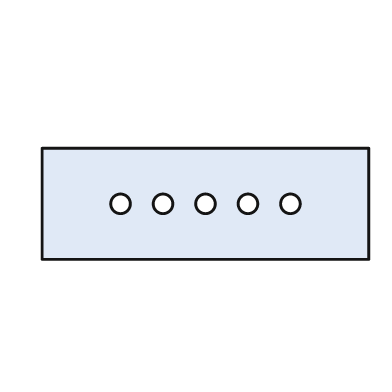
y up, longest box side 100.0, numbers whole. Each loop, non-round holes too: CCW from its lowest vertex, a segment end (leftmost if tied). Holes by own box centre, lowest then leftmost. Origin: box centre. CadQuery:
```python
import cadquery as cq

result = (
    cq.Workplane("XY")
    .moveTo(-50.0, -17.0)
    .lineTo(50.0, -17.0)
    .lineTo(50.0, 17.0)
    .lineTo(-50.0, 17.0)
    .close()
    .moveTo(-26.0, 0.0)
    .circle(3.0)
    .moveTo(-13.0, 0.0)
    .circle(3.0)
    .moveTo(0.0, 0.0)
    .circle(3.0)
    .moveTo(13.0, 0.0)
    .circle(3.0)
    .moveTo(26.0, 0.0)
    .circle(3.0)
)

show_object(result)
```